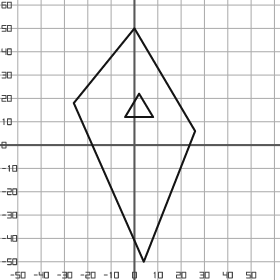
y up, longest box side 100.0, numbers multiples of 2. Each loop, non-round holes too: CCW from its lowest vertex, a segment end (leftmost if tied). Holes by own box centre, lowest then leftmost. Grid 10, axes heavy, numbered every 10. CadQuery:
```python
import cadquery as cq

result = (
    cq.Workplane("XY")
    .moveTo(4.0, -50.0)
    .lineTo(26.0, 6.0)
    .lineTo(0.0, 50.0)
    .lineTo(-26.0, 18.0)
    .close()
    .moveTo(-4.0, 12.0)
    .lineTo(8.0, 12.0)
    .lineTo(2.0, 22.0)
    .close()
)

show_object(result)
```